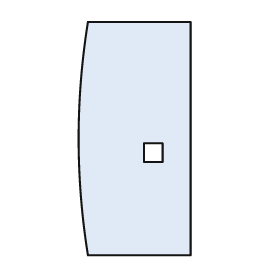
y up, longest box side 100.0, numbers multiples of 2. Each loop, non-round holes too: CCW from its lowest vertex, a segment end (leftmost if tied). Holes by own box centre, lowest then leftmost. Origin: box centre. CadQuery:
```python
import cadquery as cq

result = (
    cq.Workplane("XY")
    .moveTo(-20.0, -50.0)
    .lineTo(24.0, -50.0)
    .lineTo(24.0, 50.0)
    .lineTo(-20.0, 50.0)
    .threePointArc((-24.0, 0.0), (-20.0, -50.0))
    .close()
    .moveTo(4.0, -10.0)
    .lineTo(12.0, -10.0)
    .lineTo(12.0, -2.0)
    .lineTo(4.0, -2.0)
    .close()
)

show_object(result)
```